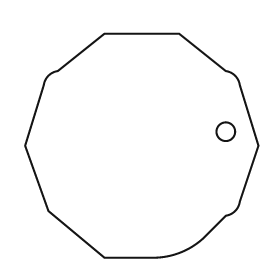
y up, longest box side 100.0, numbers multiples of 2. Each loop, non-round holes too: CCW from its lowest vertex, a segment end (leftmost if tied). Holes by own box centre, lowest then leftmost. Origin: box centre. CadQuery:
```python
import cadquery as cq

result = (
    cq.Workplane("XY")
    .moveTo(-16.0, -48.0)
    .lineTo(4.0, -48.0)
    .threePointArc((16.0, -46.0), (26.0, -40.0))
    .lineTo(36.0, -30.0)
    .threePointArc((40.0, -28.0), (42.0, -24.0))
    .lineTo(50.0, 0.0)
    .lineTo(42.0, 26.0)
    .threePointArc((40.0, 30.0), (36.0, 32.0))
    .lineTo(16.0, 48.0)
    .lineTo(-16.0, 48.0)
    .lineTo(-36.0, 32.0)
    .threePointArc((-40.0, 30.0), (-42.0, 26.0))
    .lineTo(-50.0, 0.0)
    .lineTo(-40.0, -28.0)
    .close()
    .moveTo(36.0, 6.0)
    .circle(4.0)
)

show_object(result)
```